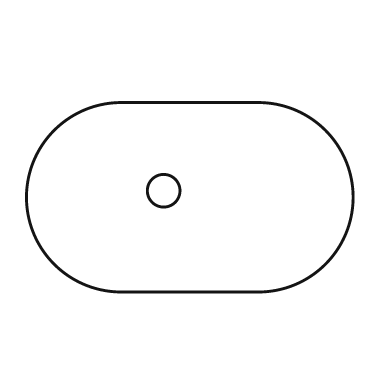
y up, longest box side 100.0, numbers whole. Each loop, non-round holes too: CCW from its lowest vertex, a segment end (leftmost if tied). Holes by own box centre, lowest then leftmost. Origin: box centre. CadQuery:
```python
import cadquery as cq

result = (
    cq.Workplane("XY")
    .moveTo(-21.0, -29.0)
    .lineTo(21.0, -29.0)
    .threePointArc((50.0, 0.0), (21.0, 29.0))
    .lineTo(-21.0, 29.0)
    .threePointArc((-50.0, 0.0), (-21.0, -29.0))
    .close()
    .moveTo(-8.0, 2.0)
    .circle(5.0)
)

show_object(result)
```